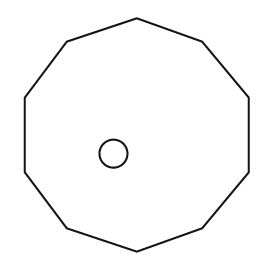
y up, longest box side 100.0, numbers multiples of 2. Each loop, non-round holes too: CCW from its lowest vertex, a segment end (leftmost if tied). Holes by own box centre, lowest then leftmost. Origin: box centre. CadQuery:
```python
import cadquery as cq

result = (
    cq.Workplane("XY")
    .moveTo(0.0, -50.0)
    .lineTo(28.0, -40.0)
    .lineTo(48.0, -16.0)
    .lineTo(48.0, 16.0)
    .lineTo(28.0, 40.0)
    .lineTo(0.0, 50.0)
    .lineTo(-30.0, 40.0)
    .lineTo(-48.0, 16.0)
    .lineTo(-48.0, -16.0)
    .lineTo(-30.0, -40.0)
    .close()
    .moveTo(-10.0, -8.0)
    .circle(6.0)
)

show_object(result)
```